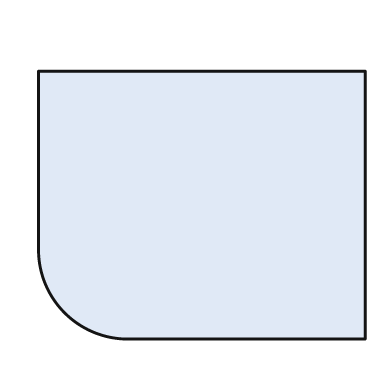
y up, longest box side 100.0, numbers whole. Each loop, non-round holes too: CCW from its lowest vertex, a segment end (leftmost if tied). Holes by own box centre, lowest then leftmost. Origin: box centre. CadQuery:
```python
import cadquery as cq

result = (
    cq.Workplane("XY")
    .moveTo(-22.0, -41.0)
    .lineTo(50.0, -41.0)
    .lineTo(50.0, 41.0)
    .lineTo(-50.0, 41.0)
    .lineTo(-50.0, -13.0)
    .threePointArc((-42.0, -33.0), (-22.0, -41.0))
    .close()
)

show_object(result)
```